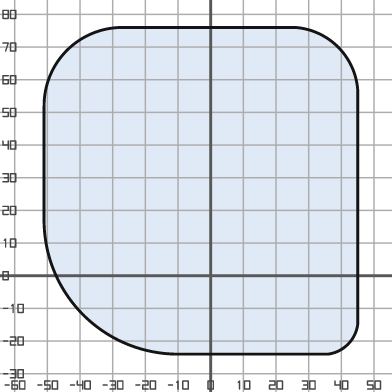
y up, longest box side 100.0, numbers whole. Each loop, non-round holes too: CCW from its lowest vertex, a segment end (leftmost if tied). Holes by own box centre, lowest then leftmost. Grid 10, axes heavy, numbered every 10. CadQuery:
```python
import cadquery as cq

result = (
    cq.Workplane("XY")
    .moveTo(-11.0, -24.0)
    .lineTo(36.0, -24.0)
    .threePointArc((42.0, -21.0), (45.0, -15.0))
    .lineTo(45.0, 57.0)
    .threePointArc((39.0, 70.0), (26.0, 76.0))
    .lineTo(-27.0, 76.0)
    .threePointArc((-44.0, 69.0), (-51.0, 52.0))
    .lineTo(-51.0, 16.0)
    .threePointArc((-39.0, -12.0), (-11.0, -24.0))
    .close()
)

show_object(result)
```